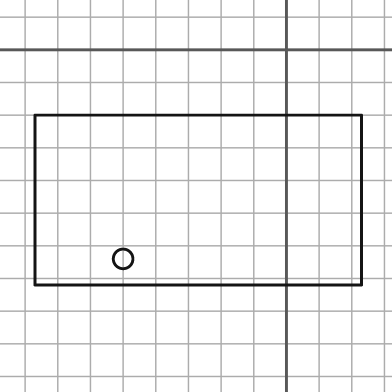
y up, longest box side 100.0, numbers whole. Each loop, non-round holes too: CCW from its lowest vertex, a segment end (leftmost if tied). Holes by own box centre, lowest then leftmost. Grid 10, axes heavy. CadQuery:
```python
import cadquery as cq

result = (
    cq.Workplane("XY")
    .moveTo(-77.0, -72.0)
    .lineTo(23.0, -72.0)
    .lineTo(23.0, -20.0)
    .lineTo(-77.0, -20.0)
    .close()
    .moveTo(-50.0, -64.0)
    .circle(3.0)
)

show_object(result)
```